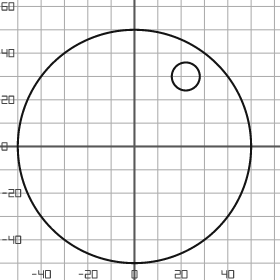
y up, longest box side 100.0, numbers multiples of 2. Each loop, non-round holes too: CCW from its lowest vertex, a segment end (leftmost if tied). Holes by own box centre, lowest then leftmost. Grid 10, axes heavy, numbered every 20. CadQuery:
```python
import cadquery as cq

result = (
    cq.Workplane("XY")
    .moveTo(0.0, 0.0)
    .circle(50.0)
    .moveTo(22.0, 30.0)
    .circle(6.0)
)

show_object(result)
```